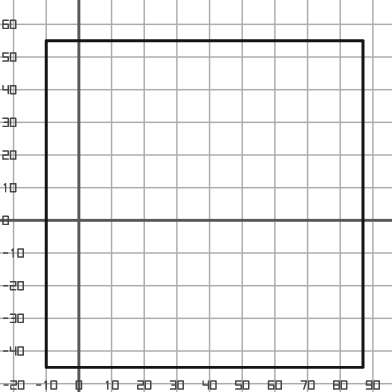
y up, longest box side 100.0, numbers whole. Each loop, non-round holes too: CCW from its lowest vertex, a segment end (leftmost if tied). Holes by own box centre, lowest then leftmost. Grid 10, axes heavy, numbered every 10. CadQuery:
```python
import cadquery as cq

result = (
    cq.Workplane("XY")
    .moveTo(-10.0, -45.0)
    .lineTo(87.0, -45.0)
    .lineTo(87.0, 55.0)
    .lineTo(-10.0, 55.0)
    .close()
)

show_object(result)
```